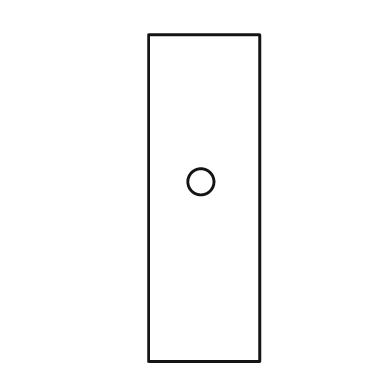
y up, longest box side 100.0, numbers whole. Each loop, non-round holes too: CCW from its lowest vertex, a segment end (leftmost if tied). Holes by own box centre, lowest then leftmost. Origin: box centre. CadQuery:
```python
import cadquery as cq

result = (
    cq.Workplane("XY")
    .moveTo(-17.0, -50.0)
    .lineTo(17.0, -50.0)
    .lineTo(17.0, 50.0)
    .lineTo(-17.0, 50.0)
    .close()
    .moveTo(-1.0, 5.0)
    .circle(4.0)
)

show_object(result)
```